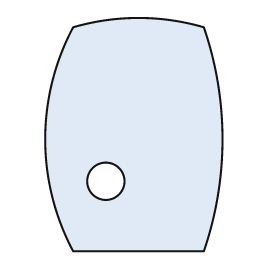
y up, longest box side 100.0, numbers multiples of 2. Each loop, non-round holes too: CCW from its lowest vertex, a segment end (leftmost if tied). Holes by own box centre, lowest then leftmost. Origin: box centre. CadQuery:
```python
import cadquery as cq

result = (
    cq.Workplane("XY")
    .moveTo(-26.0, -50.0)
    .lineTo(30.0, -50.0)
    .threePointArc((38.0, -2.0), (30.0, 46.0))
    .threePointArc((2.0, 50.0), (-26.0, 46.0))
    .threePointArc((-38.0, -2.0), (-26.0, -50.0))
    .close()
    .moveTo(-12.0, -20.0)
    .circle(8.0)
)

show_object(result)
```